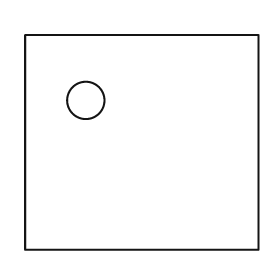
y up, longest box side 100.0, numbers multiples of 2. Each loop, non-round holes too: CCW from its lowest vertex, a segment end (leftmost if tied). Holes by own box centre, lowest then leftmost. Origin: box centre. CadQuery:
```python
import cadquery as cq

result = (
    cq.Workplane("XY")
    .moveTo(-50.0, -46.0)
    .lineTo(50.0, -46.0)
    .lineTo(50.0, 46.0)
    .lineTo(-50.0, 46.0)
    .close()
    .moveTo(-24.0, 18.0)
    .circle(8.0)
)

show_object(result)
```